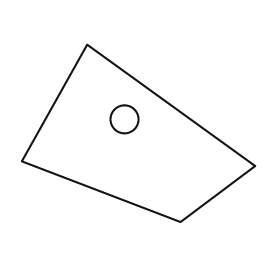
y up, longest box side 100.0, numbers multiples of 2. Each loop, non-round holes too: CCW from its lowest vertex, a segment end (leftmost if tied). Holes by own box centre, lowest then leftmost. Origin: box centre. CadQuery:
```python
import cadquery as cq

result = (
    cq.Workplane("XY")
    .moveTo(18.0, -38.0)
    .lineTo(50.0, -14.0)
    .lineTo(-22.0, 38.0)
    .lineTo(-50.0, -12.0)
    .close()
    .moveTo(-6.0, 6.0)
    .circle(6.0)
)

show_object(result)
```